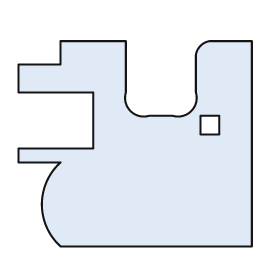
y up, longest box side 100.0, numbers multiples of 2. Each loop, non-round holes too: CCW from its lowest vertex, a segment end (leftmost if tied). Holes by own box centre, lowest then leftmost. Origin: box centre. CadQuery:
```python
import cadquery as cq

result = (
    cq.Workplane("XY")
    .moveTo(-32.0, -44.0)
    .lineTo(50.0, -44.0)
    .lineTo(50.0, 44.0)
    .lineTo(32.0, 44.0)
    .threePointArc((28.0, 42.0), (26.0, 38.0))
    .lineTo(26.0, 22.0)
    .threePointArc((24.0, 14.0), (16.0, 12.0))
    .lineTo(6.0, 12.0)
    .threePointArc((-2.0, 14.0), (-4.0, 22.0))
    .lineTo(-4.0, 44.0)
    .lineTo(-32.0, 44.0)
    .lineTo(-32.0, 34.0)
    .lineTo(-50.0, 34.0)
    .lineTo(-50.0, 22.0)
    .lineTo(-18.0, 22.0)
    .lineTo(-18.0, -2.0)
    .lineTo(-50.0, -2.0)
    .lineTo(-50.0, -8.0)
    .lineTo(-32.0, -8.0)
    .threePointArc((-40.0, -26.0), (-32.0, -44.0))
    .close()
    .moveTo(28.0, 4.0)
    .lineTo(36.0, 4.0)
    .lineTo(36.0, 12.0)
    .lineTo(28.0, 12.0)
    .close()
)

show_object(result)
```